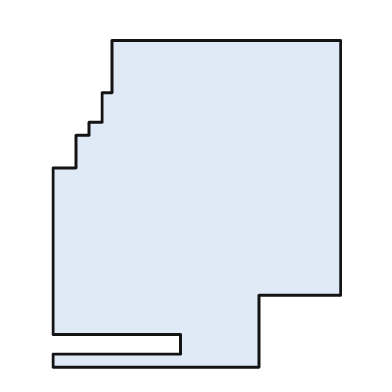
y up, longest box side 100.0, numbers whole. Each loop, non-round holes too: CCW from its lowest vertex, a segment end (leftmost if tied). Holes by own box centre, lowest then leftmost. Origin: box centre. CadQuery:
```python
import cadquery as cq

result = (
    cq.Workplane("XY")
    .moveTo(-44.0, -50.0)
    .lineTo(19.0, -50.0)
    .lineTo(19.0, -28.0)
    .lineTo(44.0, -28.0)
    .lineTo(44.0, 50.0)
    .lineTo(-26.0, 50.0)
    .lineTo(-26.0, 34.0)
    .lineTo(-29.0, 34.0)
    .lineTo(-29.0, 25.0)
    .lineTo(-33.0, 25.0)
    .lineTo(-33.0, 21.0)
    .lineTo(-37.0, 21.0)
    .lineTo(-37.0, 11.0)
    .lineTo(-44.0, 11.0)
    .lineTo(-44.0, -40.0)
    .lineTo(-5.0, -40.0)
    .lineTo(-5.0, -46.0)
    .lineTo(-44.0, -46.0)
    .close()
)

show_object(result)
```